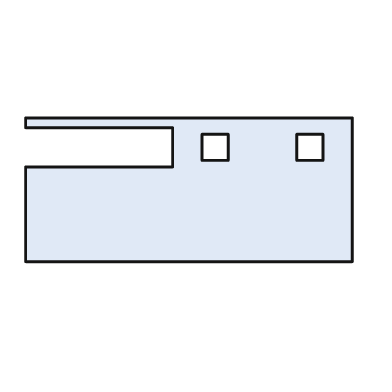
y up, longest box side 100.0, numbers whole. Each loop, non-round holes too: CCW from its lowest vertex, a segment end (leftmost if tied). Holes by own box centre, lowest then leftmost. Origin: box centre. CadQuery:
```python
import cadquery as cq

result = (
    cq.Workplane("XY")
    .moveTo(-50.0, -22.0)
    .lineTo(50.0, -22.0)
    .lineTo(50.0, 22.0)
    .lineTo(-50.0, 22.0)
    .lineTo(-50.0, 19.0)
    .lineTo(-5.0, 19.0)
    .lineTo(-5.0, 7.0)
    .lineTo(-50.0, 7.0)
    .close()
    .moveTo(4.0, 9.0)
    .lineTo(12.0, 9.0)
    .lineTo(12.0, 17.0)
    .lineTo(4.0, 17.0)
    .close()
    .moveTo(33.0, 9.0)
    .lineTo(41.0, 9.0)
    .lineTo(41.0, 17.0)
    .lineTo(33.0, 17.0)
    .close()
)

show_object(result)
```